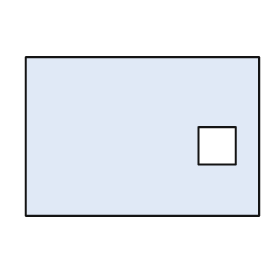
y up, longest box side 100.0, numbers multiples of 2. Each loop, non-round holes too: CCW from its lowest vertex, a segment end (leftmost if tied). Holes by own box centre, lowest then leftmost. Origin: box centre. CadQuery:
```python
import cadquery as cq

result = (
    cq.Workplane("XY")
    .moveTo(-50.0, -34.0)
    .lineTo(50.0, -34.0)
    .lineTo(50.0, 34.0)
    .lineTo(-50.0, 34.0)
    .close()
    .moveTo(24.0, -12.0)
    .lineTo(40.0, -12.0)
    .lineTo(40.0, 4.0)
    .lineTo(24.0, 4.0)
    .close()
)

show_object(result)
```